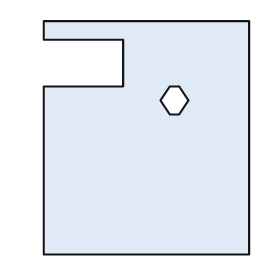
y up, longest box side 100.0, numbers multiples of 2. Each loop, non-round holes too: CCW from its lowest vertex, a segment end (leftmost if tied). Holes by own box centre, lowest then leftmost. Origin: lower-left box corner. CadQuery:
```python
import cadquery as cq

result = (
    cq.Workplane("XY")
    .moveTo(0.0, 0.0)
    .lineTo(88.0, 0.0)
    .lineTo(88.0, 100.0)
    .lineTo(0.0, 100.0)
    .lineTo(0.0, 92.0)
    .lineTo(34.0, 92.0)
    .lineTo(34.0, 72.0)
    .lineTo(0.0, 72.0)
    .close()
    .moveTo(54.0, 60.0)
    .lineTo(58.0, 60.0)
    .lineTo(62.0, 66.0)
    .lineTo(58.0, 72.0)
    .lineTo(54.0, 72.0)
    .lineTo(50.0, 66.0)
    .close()
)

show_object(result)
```